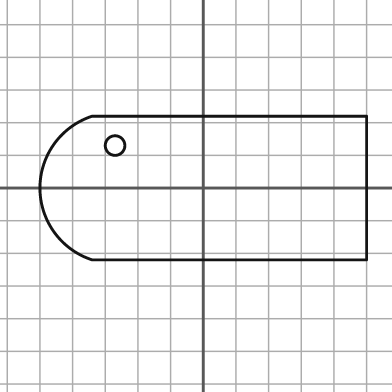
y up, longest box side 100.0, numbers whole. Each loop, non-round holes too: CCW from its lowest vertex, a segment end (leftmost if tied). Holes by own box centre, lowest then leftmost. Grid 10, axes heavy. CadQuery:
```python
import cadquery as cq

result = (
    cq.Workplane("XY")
    .moveTo(-34.0, -22.0)
    .lineTo(50.0, -22.0)
    .lineTo(50.0, 22.0)
    .lineTo(-34.0, 22.0)
    .threePointArc((-50.0, 0.0), (-34.0, -22.0))
    .close()
    .moveTo(-27.0, 13.0)
    .circle(3.0)
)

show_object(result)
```